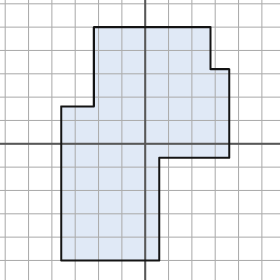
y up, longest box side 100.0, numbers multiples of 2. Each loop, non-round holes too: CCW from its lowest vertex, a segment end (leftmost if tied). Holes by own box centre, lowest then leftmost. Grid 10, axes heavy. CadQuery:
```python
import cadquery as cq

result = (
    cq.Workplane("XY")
    .moveTo(-36.0, -50.0)
    .lineTo(6.0, -50.0)
    .lineTo(6.0, -6.0)
    .lineTo(36.0, -6.0)
    .lineTo(36.0, 32.0)
    .lineTo(28.0, 32.0)
    .lineTo(28.0, 50.0)
    .lineTo(-22.0, 50.0)
    .lineTo(-22.0, 16.0)
    .lineTo(-36.0, 16.0)
    .close()
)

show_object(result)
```